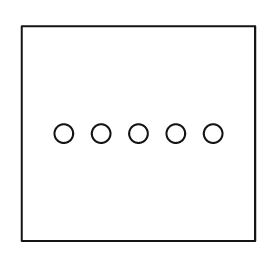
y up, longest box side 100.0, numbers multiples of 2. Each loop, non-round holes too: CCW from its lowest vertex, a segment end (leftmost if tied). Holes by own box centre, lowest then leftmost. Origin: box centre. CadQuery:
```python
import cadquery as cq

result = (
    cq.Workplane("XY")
    .moveTo(-50.0, -46.0)
    .lineTo(50.0, -46.0)
    .lineTo(50.0, 46.0)
    .lineTo(-50.0, 46.0)
    .close()
    .moveTo(-32.0, 0.0)
    .circle(4.0)
    .moveTo(-16.0, 0.0)
    .circle(4.0)
    .moveTo(0.0, 0.0)
    .circle(4.0)
    .moveTo(16.0, 0.0)
    .circle(4.0)
    .moveTo(32.0, 0.0)
    .circle(4.0)
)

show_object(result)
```